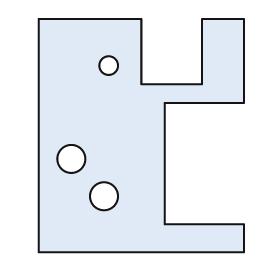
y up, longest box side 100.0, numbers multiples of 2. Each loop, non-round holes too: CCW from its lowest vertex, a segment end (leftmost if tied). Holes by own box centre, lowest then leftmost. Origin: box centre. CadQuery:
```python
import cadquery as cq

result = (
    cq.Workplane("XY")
    .moveTo(-44.0, -50.0)
    .lineTo(44.0, -50.0)
    .lineTo(44.0, -38.0)
    .lineTo(10.0, -38.0)
    .lineTo(10.0, 14.0)
    .lineTo(44.0, 14.0)
    .lineTo(44.0, 50.0)
    .lineTo(26.0, 50.0)
    .lineTo(26.0, 22.0)
    .lineTo(0.0, 22.0)
    .lineTo(0.0, 50.0)
    .lineTo(-44.0, 50.0)
    .close()
    .moveTo(-16.0, -26.0)
    .circle(6.0)
    .moveTo(-30.0, -10.0)
    .circle(6.0)
    .moveTo(-14.0, 30.0)
    .circle(4.0)
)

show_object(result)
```